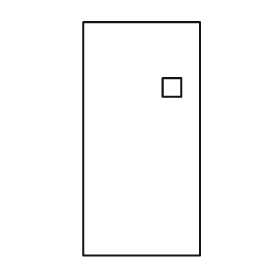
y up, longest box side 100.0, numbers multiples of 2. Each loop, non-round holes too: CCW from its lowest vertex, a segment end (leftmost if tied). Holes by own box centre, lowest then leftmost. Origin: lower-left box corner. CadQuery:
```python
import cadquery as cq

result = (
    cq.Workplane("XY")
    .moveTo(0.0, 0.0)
    .lineTo(50.0, 0.0)
    .lineTo(50.0, 100.0)
    .lineTo(0.0, 100.0)
    .close()
    .moveTo(34.0, 68.0)
    .lineTo(42.0, 68.0)
    .lineTo(42.0, 76.0)
    .lineTo(34.0, 76.0)
    .close()
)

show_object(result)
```